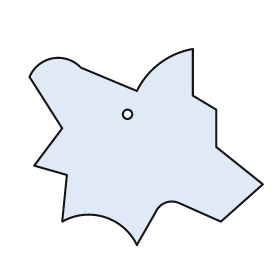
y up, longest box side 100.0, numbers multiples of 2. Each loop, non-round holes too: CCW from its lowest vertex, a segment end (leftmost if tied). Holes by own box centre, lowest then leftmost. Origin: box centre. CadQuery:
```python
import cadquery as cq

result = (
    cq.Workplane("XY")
    .moveTo(-4.0, -42.0)
    .lineTo(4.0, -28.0)
    .threePointArc((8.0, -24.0), (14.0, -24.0))
    .lineTo(32.0, -32.0)
    .lineTo(50.0, -16.0)
    .lineTo(30.0, 0.0)
    .lineTo(30.0, 16.0)
    .lineTo(20.0, 22.0)
    .lineTo(20.0, 42.0)
    .threePointArc((6.0, 36.0), (-4.0, 24.0))
    .lineTo(-28.0, 34.0)
    .threePointArc((-40.0, 38.0), (-50.0, 30.0))
    .lineTo(-36.0, 8.0)
    .lineTo(-48.0, -8.0)
    .lineTo(-34.0, -12.0)
    .lineTo(-36.0, -32.0)
    .threePointArc((-18.0, -30.0), (-4.0, -42.0))
    .close()
    .moveTo(-8.0, 14.0)
    .circle(2.0)
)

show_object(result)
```